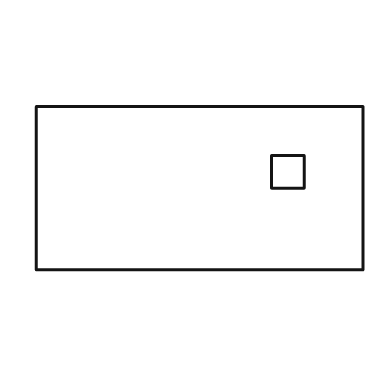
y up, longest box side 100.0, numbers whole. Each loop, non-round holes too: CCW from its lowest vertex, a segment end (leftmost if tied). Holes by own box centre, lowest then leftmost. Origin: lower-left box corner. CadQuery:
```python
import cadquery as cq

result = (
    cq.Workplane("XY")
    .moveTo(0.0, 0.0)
    .lineTo(100.0, 0.0)
    .lineTo(100.0, 50.0)
    .lineTo(0.0, 50.0)
    .close()
    .moveTo(72.0, 25.0)
    .lineTo(82.0, 25.0)
    .lineTo(82.0, 35.0)
    .lineTo(72.0, 35.0)
    .close()
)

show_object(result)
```